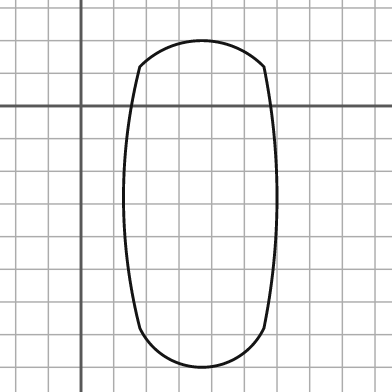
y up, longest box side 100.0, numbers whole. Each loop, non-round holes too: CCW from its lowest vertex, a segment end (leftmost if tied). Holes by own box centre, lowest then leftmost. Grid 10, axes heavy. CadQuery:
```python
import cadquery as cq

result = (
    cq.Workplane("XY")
    .moveTo(18.0, -68.0)
    .threePointArc((37.0, -80.0), (56.0, -68.0))
    .threePointArc((60.0, -28.0), (56.0, 12.0))
    .threePointArc((37.0, 20.0), (18.0, 12.0))
    .threePointArc((13.0, -28.0), (18.0, -68.0))
    .close()
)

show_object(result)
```